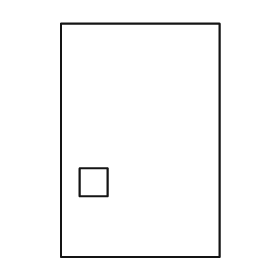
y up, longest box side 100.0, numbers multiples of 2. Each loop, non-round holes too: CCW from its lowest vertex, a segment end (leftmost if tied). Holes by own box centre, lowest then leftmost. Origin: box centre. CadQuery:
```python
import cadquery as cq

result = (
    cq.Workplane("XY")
    .moveTo(-34.0, -50.0)
    .lineTo(34.0, -50.0)
    .lineTo(34.0, 50.0)
    .lineTo(-34.0, 50.0)
    .close()
    .moveTo(-26.0, -24.0)
    .lineTo(-14.0, -24.0)
    .lineTo(-14.0, -12.0)
    .lineTo(-26.0, -12.0)
    .close()
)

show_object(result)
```